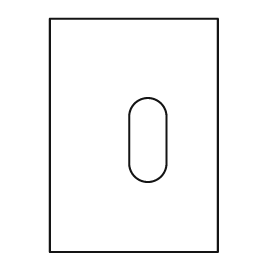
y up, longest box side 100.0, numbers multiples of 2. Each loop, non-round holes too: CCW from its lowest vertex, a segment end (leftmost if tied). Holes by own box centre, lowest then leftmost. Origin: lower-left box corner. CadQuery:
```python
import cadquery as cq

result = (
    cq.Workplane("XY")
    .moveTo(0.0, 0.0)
    .lineTo(72.0, 0.0)
    .lineTo(72.0, 100.0)
    .lineTo(0.0, 100.0)
    .close()
    .moveTo(34.0, 38.0)
    .threePointArc((42.0, 30.0), (50.0, 38.0))
    .lineTo(50.0, 58.0)
    .threePointArc((42.0, 66.0), (34.0, 58.0))
    .close()
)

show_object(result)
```